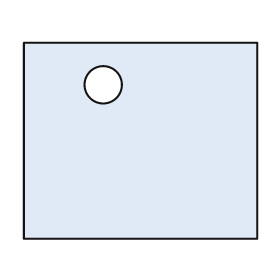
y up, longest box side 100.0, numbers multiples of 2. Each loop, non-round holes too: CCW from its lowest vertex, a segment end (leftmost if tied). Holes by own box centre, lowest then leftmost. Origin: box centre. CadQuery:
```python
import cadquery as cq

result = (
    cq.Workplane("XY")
    .moveTo(-50.0, -42.0)
    .lineTo(50.0, -42.0)
    .lineTo(50.0, 42.0)
    .lineTo(-50.0, 42.0)
    .close()
    .moveTo(-16.0, 24.0)
    .circle(8.0)
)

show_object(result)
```